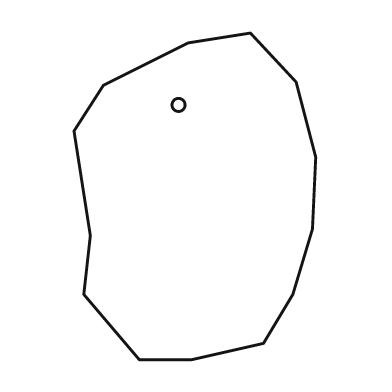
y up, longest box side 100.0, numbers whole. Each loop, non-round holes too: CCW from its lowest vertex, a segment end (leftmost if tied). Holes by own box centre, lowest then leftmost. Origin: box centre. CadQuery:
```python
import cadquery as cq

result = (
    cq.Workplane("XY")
    .moveTo(-17.0, -50.0)
    .lineTo(-1.0, -50.0)
    .lineTo(21.0, -45.0)
    .lineTo(30.0, -30.0)
    .lineTo(36.0, -10.0)
    .lineTo(37.0, 12.0)
    .lineTo(31.0, 35.0)
    .lineTo(17.0, 50.0)
    .lineTo(-2.0, 47.0)
    .lineTo(-28.0, 34.0)
    .lineTo(-37.0, 20.0)
    .lineTo(-32.0, -12.0)
    .lineTo(-34.0, -30.0)
    .close()
    .moveTo(-5.0, 28.0)
    .circle(2.0)
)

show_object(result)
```